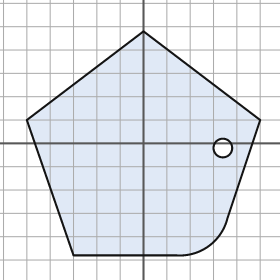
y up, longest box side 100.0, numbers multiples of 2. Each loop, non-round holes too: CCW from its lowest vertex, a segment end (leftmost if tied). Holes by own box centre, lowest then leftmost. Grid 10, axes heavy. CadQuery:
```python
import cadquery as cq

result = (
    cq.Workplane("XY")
    .moveTo(-30.0, -48.0)
    .lineTo(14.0, -48.0)
    .threePointArc((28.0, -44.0), (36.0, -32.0))
    .lineTo(50.0, 10.0)
    .lineTo(0.0, 48.0)
    .lineTo(-50.0, 10.0)
    .close()
    .moveTo(34.0, -2.0)
    .circle(4.0)
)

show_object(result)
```